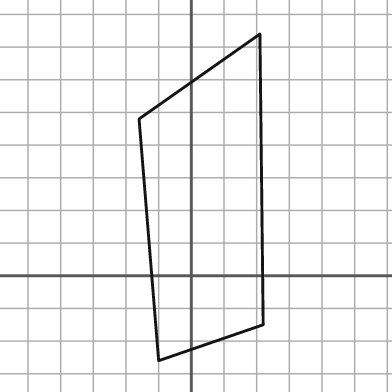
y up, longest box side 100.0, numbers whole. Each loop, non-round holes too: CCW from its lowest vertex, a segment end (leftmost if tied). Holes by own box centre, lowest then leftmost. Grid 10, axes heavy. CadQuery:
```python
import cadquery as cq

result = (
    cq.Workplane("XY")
    .moveTo(-10.0, -26.0)
    .lineTo(22.0, -15.0)
    .lineTo(21.0, 74.0)
    .lineTo(-16.0, 48.0)
    .close()
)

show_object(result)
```